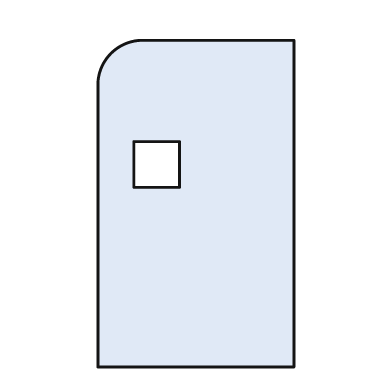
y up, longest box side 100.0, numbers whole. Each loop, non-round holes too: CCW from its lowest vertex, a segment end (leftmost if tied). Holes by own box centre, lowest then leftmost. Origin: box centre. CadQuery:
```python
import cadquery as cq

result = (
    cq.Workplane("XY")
    .moveTo(-30.0, -50.0)
    .lineTo(30.0, -50.0)
    .lineTo(30.0, 50.0)
    .lineTo(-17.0, 50.0)
    .threePointArc((-26.0, 46.0), (-30.0, 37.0))
    .close()
    .moveTo(-19.0, 5.0)
    .lineTo(-5.0, 5.0)
    .lineTo(-5.0, 19.0)
    .lineTo(-19.0, 19.0)
    .close()
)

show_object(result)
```